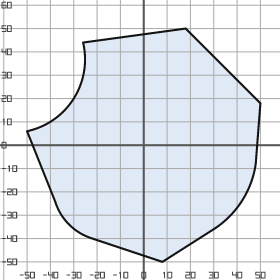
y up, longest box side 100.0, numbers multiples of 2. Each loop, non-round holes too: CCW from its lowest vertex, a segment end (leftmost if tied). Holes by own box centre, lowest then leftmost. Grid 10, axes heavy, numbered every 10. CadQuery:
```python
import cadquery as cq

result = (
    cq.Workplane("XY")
    .moveTo(8.0, -50.0)
    .lineTo(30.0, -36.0)
    .threePointArc((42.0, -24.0), (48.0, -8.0))
    .lineTo(50.0, 18.0)
    .lineTo(18.0, 50.0)
    .lineTo(-26.0, 44.0)
    .threePointArc((-30.0, 20.0), (-50.0, 6.0))
    .lineTo(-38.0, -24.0)
    .threePointArc((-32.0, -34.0), (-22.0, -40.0))
    .close()
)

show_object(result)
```